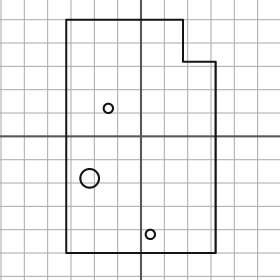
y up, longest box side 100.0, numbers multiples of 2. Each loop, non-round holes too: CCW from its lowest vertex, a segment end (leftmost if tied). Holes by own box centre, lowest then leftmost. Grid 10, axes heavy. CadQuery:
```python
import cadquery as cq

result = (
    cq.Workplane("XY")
    .moveTo(-32.0, -50.0)
    .lineTo(32.0, -50.0)
    .lineTo(32.0, 32.0)
    .lineTo(18.0, 32.0)
    .lineTo(18.0, 50.0)
    .lineTo(-32.0, 50.0)
    .close()
    .moveTo(4.0, -42.0)
    .circle(2.0)
    .moveTo(-22.0, -18.0)
    .circle(4.0)
    .moveTo(-14.0, 12.0)
    .circle(2.0)
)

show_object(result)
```